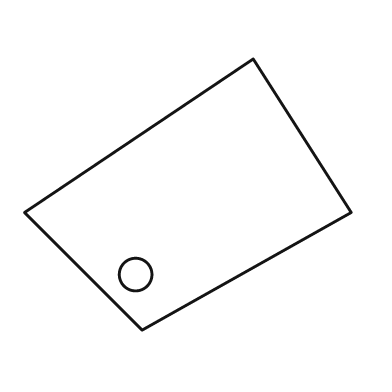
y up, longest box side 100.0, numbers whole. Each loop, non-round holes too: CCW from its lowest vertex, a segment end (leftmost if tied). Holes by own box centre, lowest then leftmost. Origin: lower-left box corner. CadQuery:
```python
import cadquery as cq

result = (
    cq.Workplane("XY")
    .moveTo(36.0, 0.0)
    .lineTo(100.0, 36.0)
    .lineTo(70.0, 83.0)
    .lineTo(0.0, 36.0)
    .close()
    .moveTo(34.0, 17.0)
    .circle(5.0)
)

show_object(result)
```